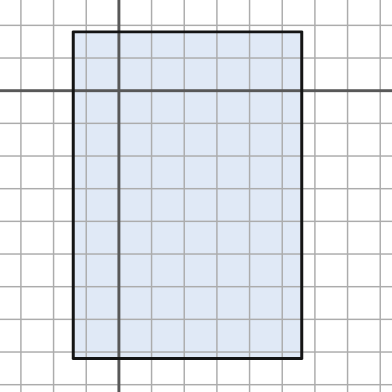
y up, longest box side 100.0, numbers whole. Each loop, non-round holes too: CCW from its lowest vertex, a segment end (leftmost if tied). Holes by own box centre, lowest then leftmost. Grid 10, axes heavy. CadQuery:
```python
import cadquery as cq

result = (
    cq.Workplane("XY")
    .moveTo(-14.0, -82.0)
    .lineTo(56.0, -82.0)
    .lineTo(56.0, 18.0)
    .lineTo(-14.0, 18.0)
    .close()
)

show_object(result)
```